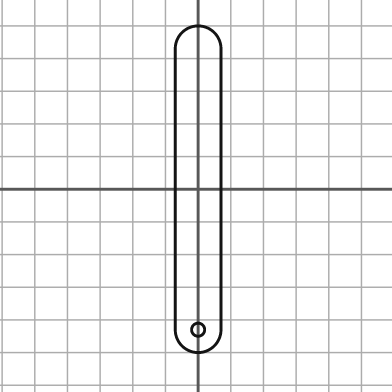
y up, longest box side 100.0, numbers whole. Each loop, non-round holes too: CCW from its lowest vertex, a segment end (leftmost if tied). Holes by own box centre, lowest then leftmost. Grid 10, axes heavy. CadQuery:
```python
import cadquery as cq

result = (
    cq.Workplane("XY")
    .moveTo(-7.0, -43.0)
    .threePointArc((0.0, -50.0), (7.0, -43.0))
    .lineTo(7.0, 43.0)
    .threePointArc((0.0, 50.0), (-7.0, 43.0))
    .close()
    .moveTo(0.0, -43.0)
    .circle(2.0)
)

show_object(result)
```